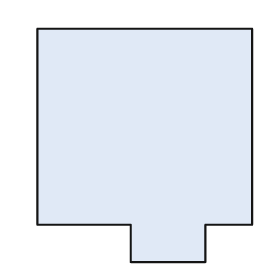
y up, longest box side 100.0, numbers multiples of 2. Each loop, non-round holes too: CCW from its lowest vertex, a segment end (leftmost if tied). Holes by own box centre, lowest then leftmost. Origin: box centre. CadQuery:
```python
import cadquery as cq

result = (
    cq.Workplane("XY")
    .moveTo(-6.0, -50.0)
    .lineTo(26.0, -50.0)
    .lineTo(26.0, -34.0)
    .lineTo(46.0, -34.0)
    .lineTo(46.0, 50.0)
    .lineTo(-46.0, 50.0)
    .lineTo(-46.0, -34.0)
    .lineTo(-6.0, -34.0)
    .close()
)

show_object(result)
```